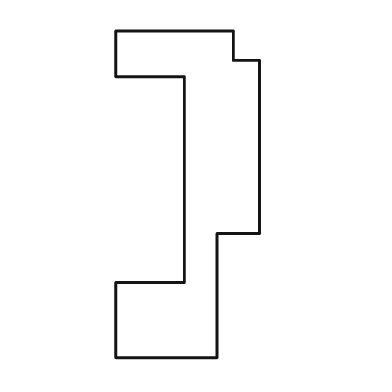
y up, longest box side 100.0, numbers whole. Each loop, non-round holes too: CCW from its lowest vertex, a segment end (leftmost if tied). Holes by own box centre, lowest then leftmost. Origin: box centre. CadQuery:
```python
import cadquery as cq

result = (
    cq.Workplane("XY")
    .moveTo(-22.0, -50.0)
    .lineTo(9.0, -50.0)
    .lineTo(9.0, -12.0)
    .lineTo(22.0, -12.0)
    .lineTo(22.0, 41.0)
    .lineTo(14.0, 41.0)
    .lineTo(14.0, 50.0)
    .lineTo(-22.0, 50.0)
    .lineTo(-22.0, 36.0)
    .lineTo(-1.0, 36.0)
    .lineTo(-1.0, -27.0)
    .lineTo(-22.0, -27.0)
    .close()
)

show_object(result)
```